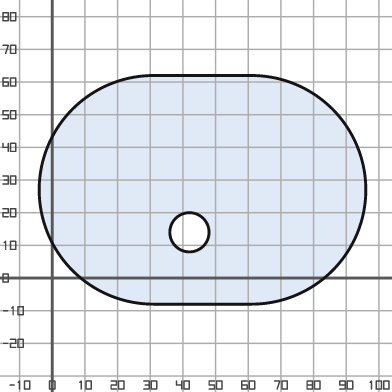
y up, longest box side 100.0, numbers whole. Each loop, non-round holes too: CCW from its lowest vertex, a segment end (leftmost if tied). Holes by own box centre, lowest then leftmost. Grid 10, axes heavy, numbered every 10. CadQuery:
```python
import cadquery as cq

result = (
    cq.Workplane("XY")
    .moveTo(31.0, -8.0)
    .lineTo(61.0, -8.0)
    .threePointArc((96.0, 27.0), (61.0, 62.0))
    .lineTo(31.0, 62.0)
    .threePointArc((-4.0, 27.0), (31.0, -8.0))
    .close()
    .moveTo(42.0, 14.0)
    .circle(6.0)
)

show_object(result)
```